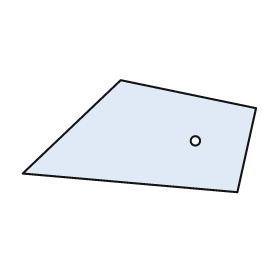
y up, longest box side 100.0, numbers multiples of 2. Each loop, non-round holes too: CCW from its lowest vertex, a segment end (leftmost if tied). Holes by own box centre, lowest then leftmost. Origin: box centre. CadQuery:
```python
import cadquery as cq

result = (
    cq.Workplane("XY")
    .moveTo(42.0, -24.0)
    .lineTo(50.0, 12.0)
    .lineTo(-8.0, 24.0)
    .lineTo(-50.0, -16.0)
    .close()
    .moveTo(24.0, -2.0)
    .circle(2.0)
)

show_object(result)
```